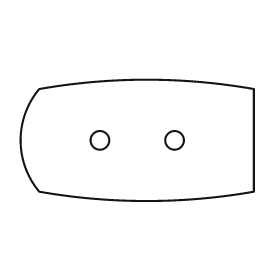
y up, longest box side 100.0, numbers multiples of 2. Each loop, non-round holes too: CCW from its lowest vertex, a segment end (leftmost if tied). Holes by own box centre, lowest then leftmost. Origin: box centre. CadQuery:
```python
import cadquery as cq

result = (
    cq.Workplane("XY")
    .moveTo(-42.0, -22.0)
    .threePointArc((4.0, -26.0), (50.0, -22.0))
    .lineTo(50.0, 22.0)
    .threePointArc((4.0, 26.0), (-42.0, 22.0))
    .threePointArc((-50.0, 0.0), (-42.0, -22.0))
    .close()
    .moveTo(-16.0, 0.0)
    .circle(4.0)
    .moveTo(16.0, 0.0)
    .circle(4.0)
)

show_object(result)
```